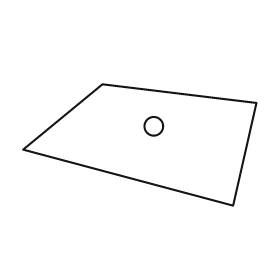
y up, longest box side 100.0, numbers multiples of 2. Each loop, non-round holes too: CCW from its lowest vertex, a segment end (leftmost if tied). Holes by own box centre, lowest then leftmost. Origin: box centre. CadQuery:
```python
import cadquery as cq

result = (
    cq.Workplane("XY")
    .moveTo(40.0, -26.0)
    .lineTo(50.0, 18.0)
    .lineTo(-16.0, 26.0)
    .lineTo(-50.0, -2.0)
    .close()
    .moveTo(6.0, 8.0)
    .circle(4.0)
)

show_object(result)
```